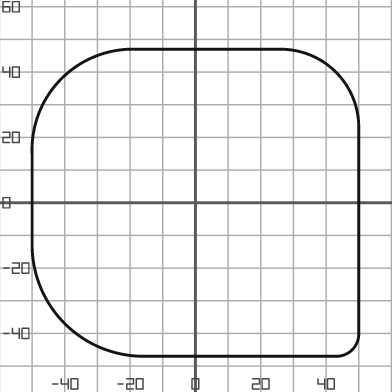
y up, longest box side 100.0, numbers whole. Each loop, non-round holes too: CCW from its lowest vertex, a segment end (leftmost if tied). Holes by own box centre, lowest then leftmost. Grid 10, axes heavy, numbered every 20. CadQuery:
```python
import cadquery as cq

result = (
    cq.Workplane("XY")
    .moveTo(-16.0, -47.0)
    .lineTo(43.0, -47.0)
    .threePointArc((48.0, -45.0), (50.0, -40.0))
    .lineTo(50.0, 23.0)
    .threePointArc((43.0, 40.0), (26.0, 47.0))
    .lineTo(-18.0, 47.0)
    .threePointArc((-41.0, 38.0), (-50.0, 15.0))
    .lineTo(-50.0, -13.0)
    .threePointArc((-40.0, -37.0), (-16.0, -47.0))
    .close()
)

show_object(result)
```